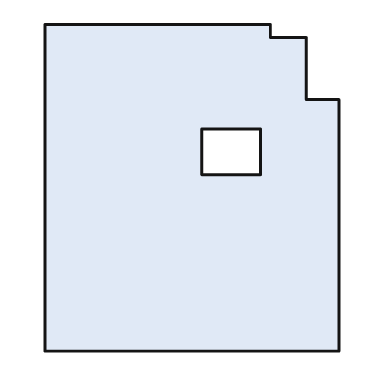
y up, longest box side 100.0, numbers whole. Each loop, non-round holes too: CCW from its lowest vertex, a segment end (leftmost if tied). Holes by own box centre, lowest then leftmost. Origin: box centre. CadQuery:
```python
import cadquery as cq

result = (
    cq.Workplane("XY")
    .moveTo(-45.0, -50.0)
    .lineTo(45.0, -50.0)
    .lineTo(45.0, 27.0)
    .lineTo(35.0, 27.0)
    .lineTo(35.0, 46.0)
    .lineTo(24.0, 46.0)
    .lineTo(24.0, 50.0)
    .lineTo(-45.0, 50.0)
    .close()
    .moveTo(3.0, 4.0)
    .lineTo(21.0, 4.0)
    .lineTo(21.0, 18.0)
    .lineTo(3.0, 18.0)
    .close()
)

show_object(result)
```